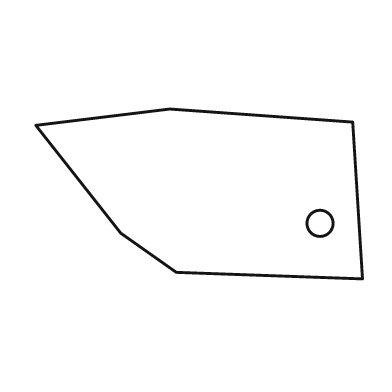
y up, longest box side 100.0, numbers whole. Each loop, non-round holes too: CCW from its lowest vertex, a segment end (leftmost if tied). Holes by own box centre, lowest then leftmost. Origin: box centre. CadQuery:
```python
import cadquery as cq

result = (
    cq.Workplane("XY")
    .moveTo(50.0, -26.0)
    .lineTo(47.0, 22.0)
    .lineTo(-9.0, 26.0)
    .lineTo(-50.0, 21.0)
    .lineTo(-24.0, -12.0)
    .lineTo(-7.0, -24.0)
    .close()
    .moveTo(37.0, -9.0)
    .circle(4.0)
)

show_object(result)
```